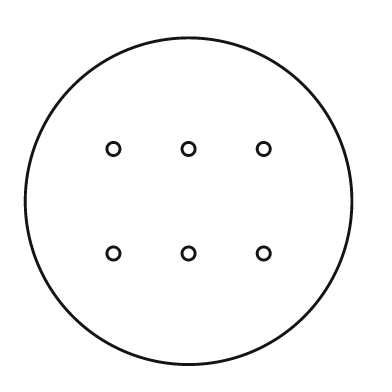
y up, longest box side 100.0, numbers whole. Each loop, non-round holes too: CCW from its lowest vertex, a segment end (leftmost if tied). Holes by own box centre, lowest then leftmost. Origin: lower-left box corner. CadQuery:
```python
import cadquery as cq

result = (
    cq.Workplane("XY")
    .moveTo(50.0, 50.0)
    .circle(50.0)
    .moveTo(27.0, 34.0)
    .circle(2.0)
    .moveTo(50.0, 34.0)
    .circle(2.0)
    .moveTo(73.0, 34.0)
    .circle(2.0)
    .moveTo(27.0, 66.0)
    .circle(2.0)
    .moveTo(50.0, 66.0)
    .circle(2.0)
    .moveTo(73.0, 66.0)
    .circle(2.0)
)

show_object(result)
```